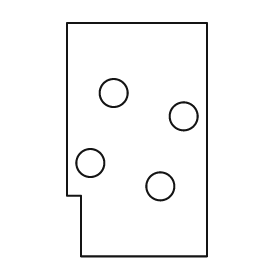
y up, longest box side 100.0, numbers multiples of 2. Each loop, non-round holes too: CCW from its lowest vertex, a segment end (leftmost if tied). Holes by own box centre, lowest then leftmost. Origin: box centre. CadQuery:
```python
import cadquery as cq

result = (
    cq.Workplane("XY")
    .moveTo(-24.0, -50.0)
    .lineTo(30.0, -50.0)
    .lineTo(30.0, 50.0)
    .lineTo(-30.0, 50.0)
    .lineTo(-30.0, -24.0)
    .lineTo(-24.0, -24.0)
    .close()
    .moveTo(10.0, -20.0)
    .circle(6.0)
    .moveTo(-20.0, -10.0)
    .circle(6.0)
    .moveTo(20.0, 10.0)
    .circle(6.0)
    .moveTo(-10.0, 20.0)
    .circle(6.0)
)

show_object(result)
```